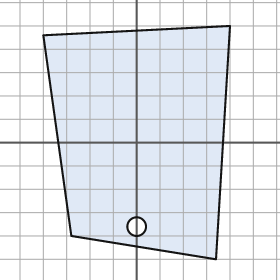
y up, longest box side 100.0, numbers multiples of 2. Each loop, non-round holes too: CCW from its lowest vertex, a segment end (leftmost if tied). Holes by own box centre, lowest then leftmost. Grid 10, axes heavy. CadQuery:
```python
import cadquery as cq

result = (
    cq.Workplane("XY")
    .moveTo(34.0, -50.0)
    .lineTo(40.0, 50.0)
    .lineTo(-40.0, 46.0)
    .lineTo(-28.0, -40.0)
    .close()
    .moveTo(0.0, -36.0)
    .circle(4.0)
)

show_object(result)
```